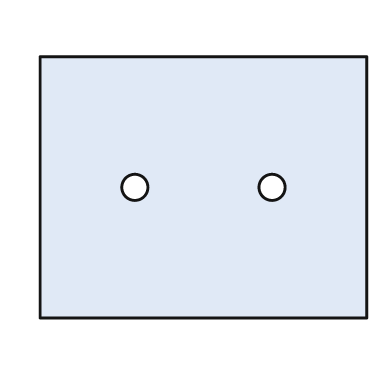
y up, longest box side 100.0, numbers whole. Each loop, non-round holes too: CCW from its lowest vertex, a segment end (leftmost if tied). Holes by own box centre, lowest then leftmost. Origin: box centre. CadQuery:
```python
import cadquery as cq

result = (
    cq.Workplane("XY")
    .moveTo(-50.0, -40.0)
    .lineTo(50.0, -40.0)
    .lineTo(50.0, 40.0)
    .lineTo(-50.0, 40.0)
    .close()
    .moveTo(-21.0, 0.0)
    .circle(4.0)
    .moveTo(21.0, 0.0)
    .circle(4.0)
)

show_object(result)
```